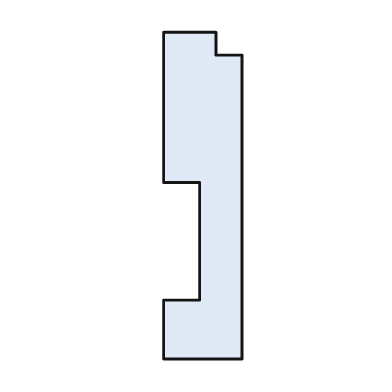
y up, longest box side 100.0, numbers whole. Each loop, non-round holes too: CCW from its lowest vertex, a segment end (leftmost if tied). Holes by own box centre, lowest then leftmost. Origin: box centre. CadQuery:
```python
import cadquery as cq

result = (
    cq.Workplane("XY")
    .moveTo(-12.0, -50.0)
    .lineTo(12.0, -50.0)
    .lineTo(12.0, 43.0)
    .lineTo(4.0, 43.0)
    .lineTo(4.0, 50.0)
    .lineTo(-12.0, 50.0)
    .lineTo(-12.0, 4.0)
    .lineTo(-1.0, 4.0)
    .lineTo(-1.0, -32.0)
    .lineTo(-12.0, -32.0)
    .close()
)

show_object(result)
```